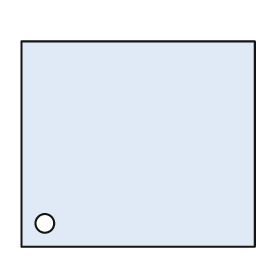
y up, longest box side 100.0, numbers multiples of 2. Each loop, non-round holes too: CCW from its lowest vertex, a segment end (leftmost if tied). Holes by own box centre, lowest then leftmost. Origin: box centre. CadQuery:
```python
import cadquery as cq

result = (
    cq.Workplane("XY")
    .moveTo(-50.0, -44.0)
    .lineTo(50.0, -44.0)
    .lineTo(50.0, 44.0)
    .lineTo(-50.0, 44.0)
    .close()
    .moveTo(-40.0, -34.0)
    .circle(4.0)
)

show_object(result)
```